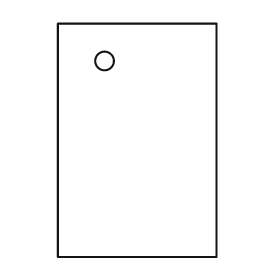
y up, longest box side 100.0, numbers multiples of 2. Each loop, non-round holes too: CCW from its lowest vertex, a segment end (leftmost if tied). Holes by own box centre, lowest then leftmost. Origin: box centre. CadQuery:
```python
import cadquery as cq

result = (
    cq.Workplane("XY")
    .moveTo(-34.0, -50.0)
    .lineTo(34.0, -50.0)
    .lineTo(34.0, 50.0)
    .lineTo(-34.0, 50.0)
    .close()
    .moveTo(-14.0, 34.0)
    .circle(4.0)
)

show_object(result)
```